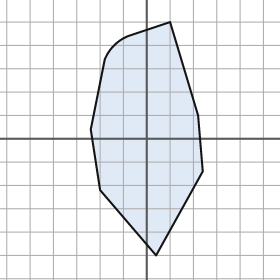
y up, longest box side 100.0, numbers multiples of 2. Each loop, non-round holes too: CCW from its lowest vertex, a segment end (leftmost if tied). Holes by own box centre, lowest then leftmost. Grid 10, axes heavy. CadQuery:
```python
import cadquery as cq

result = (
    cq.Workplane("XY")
    .moveTo(4.0, -50.0)
    .lineTo(24.0, -14.0)
    .lineTo(22.0, 10.0)
    .lineTo(10.0, 50.0)
    .lineTo(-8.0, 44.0)
    .threePointArc((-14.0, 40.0), (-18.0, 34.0))
    .lineTo(-24.0, 4.0)
    .lineTo(-20.0, -22.0)
    .close()
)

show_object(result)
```